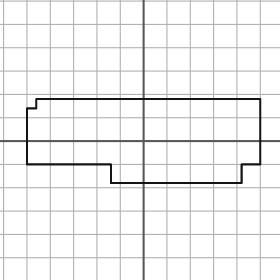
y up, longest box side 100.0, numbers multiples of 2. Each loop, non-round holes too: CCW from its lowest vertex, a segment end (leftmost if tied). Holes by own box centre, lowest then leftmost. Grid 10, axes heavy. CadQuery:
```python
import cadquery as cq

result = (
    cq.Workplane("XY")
    .moveTo(-14.0, -18.0)
    .lineTo(42.0, -18.0)
    .lineTo(42.0, -10.0)
    .lineTo(50.0, -10.0)
    .lineTo(50.0, 18.0)
    .lineTo(-46.0, 18.0)
    .lineTo(-46.0, 14.0)
    .lineTo(-50.0, 14.0)
    .lineTo(-50.0, -10.0)
    .lineTo(-14.0, -10.0)
    .close()
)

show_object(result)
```